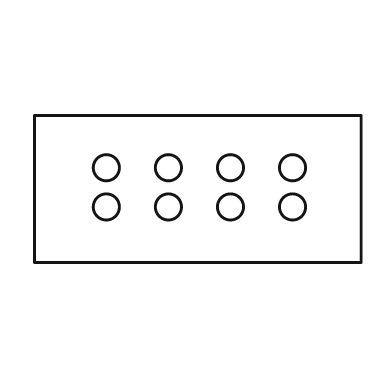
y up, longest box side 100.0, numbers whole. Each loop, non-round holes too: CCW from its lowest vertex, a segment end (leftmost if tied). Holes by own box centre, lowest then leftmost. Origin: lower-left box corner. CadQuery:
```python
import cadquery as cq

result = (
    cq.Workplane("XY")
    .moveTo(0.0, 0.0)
    .lineTo(100.0, 0.0)
    .lineTo(100.0, 45.0)
    .lineTo(0.0, 45.0)
    .close()
    .moveTo(22.0, 17.0)
    .circle(4.0)
    .moveTo(41.0, 17.0)
    .circle(4.0)
    .moveTo(60.0, 17.0)
    .circle(4.0)
    .moveTo(79.0, 17.0)
    .circle(4.0)
    .moveTo(22.0, 29.0)
    .circle(4.0)
    .moveTo(41.0, 29.0)
    .circle(4.0)
    .moveTo(60.0, 29.0)
    .circle(4.0)
    .moveTo(79.0, 29.0)
    .circle(4.0)
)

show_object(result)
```